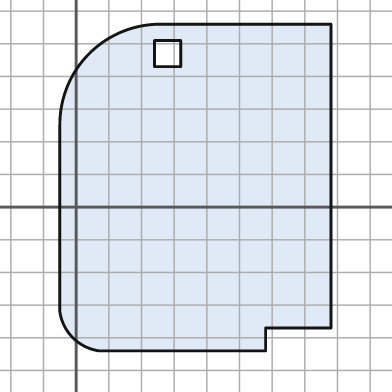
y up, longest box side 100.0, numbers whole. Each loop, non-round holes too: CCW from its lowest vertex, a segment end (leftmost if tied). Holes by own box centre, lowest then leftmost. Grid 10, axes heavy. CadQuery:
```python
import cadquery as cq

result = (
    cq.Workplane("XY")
    .moveTo(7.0, -44.0)
    .lineTo(58.0, -44.0)
    .lineTo(58.0, -37.0)
    .lineTo(78.0, -37.0)
    .lineTo(78.0, 56.0)
    .lineTo(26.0, 56.0)
    .threePointArc((4.0, 47.0), (-5.0, 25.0))
    .lineTo(-5.0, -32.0)
    .threePointArc((-1.0, -40.0), (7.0, -44.0))
    .close()
    .moveTo(24.0, 43.0)
    .lineTo(32.0, 43.0)
    .lineTo(32.0, 51.0)
    .lineTo(24.0, 51.0)
    .close()
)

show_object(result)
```